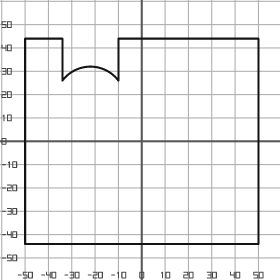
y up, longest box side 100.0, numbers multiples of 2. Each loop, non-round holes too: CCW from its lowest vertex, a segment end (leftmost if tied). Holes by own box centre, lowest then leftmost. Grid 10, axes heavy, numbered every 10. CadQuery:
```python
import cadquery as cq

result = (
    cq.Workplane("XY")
    .moveTo(-50.0, -44.0)
    .lineTo(50.0, -44.0)
    .lineTo(50.0, 44.0)
    .lineTo(-10.0, 44.0)
    .lineTo(-10.0, 26.0)
    .threePointArc((-22.0, 32.0), (-34.0, 26.0))
    .lineTo(-34.0, 44.0)
    .lineTo(-50.0, 44.0)
    .close()
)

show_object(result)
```